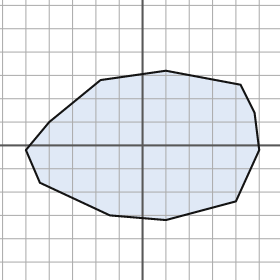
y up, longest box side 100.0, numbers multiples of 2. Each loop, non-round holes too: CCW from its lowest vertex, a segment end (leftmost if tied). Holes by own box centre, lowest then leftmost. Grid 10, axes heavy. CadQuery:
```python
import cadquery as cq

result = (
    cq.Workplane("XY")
    .moveTo(10.0, -32.0)
    .lineTo(40.0, -24.0)
    .lineTo(50.0, -2.0)
    .lineTo(48.0, 14.0)
    .lineTo(42.0, 26.0)
    .lineTo(10.0, 32.0)
    .lineTo(-18.0, 28.0)
    .lineTo(-40.0, 10.0)
    .lineTo(-50.0, -2.0)
    .lineTo(-44.0, -16.0)
    .lineTo(-14.0, -30.0)
    .close()
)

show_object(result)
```